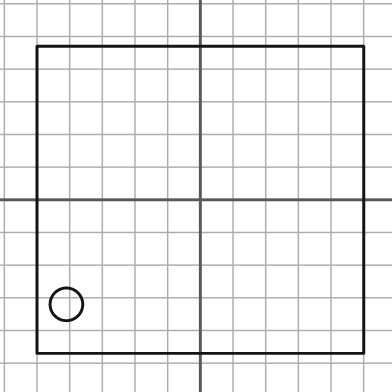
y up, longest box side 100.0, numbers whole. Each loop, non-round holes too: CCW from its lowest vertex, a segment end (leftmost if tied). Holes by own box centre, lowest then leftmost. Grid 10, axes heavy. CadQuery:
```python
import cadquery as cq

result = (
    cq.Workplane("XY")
    .moveTo(-50.0, -47.0)
    .lineTo(50.0, -47.0)
    .lineTo(50.0, 47.0)
    .lineTo(-50.0, 47.0)
    .close()
    .moveTo(-41.0, -32.0)
    .circle(5.0)
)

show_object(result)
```